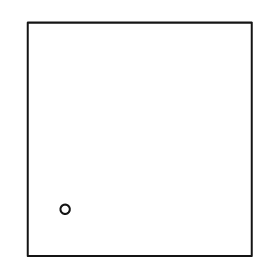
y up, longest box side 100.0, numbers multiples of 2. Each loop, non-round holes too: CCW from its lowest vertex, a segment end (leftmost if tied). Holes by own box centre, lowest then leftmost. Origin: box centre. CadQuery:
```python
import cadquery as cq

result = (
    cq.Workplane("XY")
    .moveTo(-48.0, -50.0)
    .lineTo(48.0, -50.0)
    .lineTo(48.0, 50.0)
    .lineTo(-48.0, 50.0)
    .close()
    .moveTo(-32.0, -30.0)
    .circle(2.0)
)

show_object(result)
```